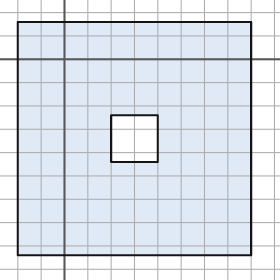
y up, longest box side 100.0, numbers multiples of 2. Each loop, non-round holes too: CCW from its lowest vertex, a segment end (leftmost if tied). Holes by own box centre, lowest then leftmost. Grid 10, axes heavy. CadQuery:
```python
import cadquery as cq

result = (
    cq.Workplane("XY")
    .moveTo(-20.0, -84.0)
    .lineTo(80.0, -84.0)
    .lineTo(80.0, 16.0)
    .lineTo(-20.0, 16.0)
    .close()
    .moveTo(20.0, -44.0)
    .lineTo(40.0, -44.0)
    .lineTo(40.0, -24.0)
    .lineTo(20.0, -24.0)
    .close()
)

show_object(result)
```